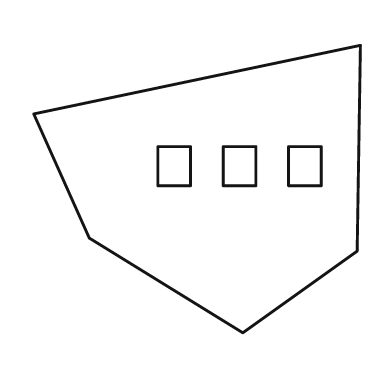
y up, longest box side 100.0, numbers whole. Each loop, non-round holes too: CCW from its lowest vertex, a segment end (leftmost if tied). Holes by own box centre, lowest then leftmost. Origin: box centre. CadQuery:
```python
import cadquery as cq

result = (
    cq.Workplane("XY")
    .moveTo(14.0, -44.0)
    .lineTo(49.0, -19.0)
    .lineTo(50.0, 44.0)
    .lineTo(-50.0, 23.0)
    .lineTo(-33.0, -15.0)
    .close()
    .moveTo(-12.0, 1.0)
    .lineTo(-2.0, 1.0)
    .lineTo(-2.0, 13.0)
    .lineTo(-12.0, 13.0)
    .close()
    .moveTo(8.0, 1.0)
    .lineTo(18.0, 1.0)
    .lineTo(18.0, 13.0)
    .lineTo(8.0, 13.0)
    .close()
    .moveTo(28.0, 1.0)
    .lineTo(38.0, 1.0)
    .lineTo(38.0, 13.0)
    .lineTo(28.0, 13.0)
    .close()
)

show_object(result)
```